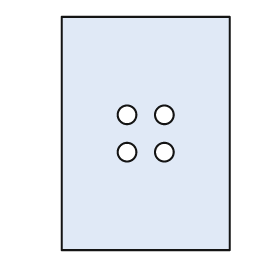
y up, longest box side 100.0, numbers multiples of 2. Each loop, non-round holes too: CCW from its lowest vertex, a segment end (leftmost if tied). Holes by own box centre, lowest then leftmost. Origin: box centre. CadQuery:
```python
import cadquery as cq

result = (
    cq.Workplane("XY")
    .moveTo(-36.0, -50.0)
    .lineTo(36.0, -50.0)
    .lineTo(36.0, 50.0)
    .lineTo(-36.0, 50.0)
    .close()
    .moveTo(-8.0, -8.0)
    .circle(4.0)
    .moveTo(8.0, -8.0)
    .circle(4.0)
    .moveTo(-8.0, 8.0)
    .circle(4.0)
    .moveTo(8.0, 8.0)
    .circle(4.0)
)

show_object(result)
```